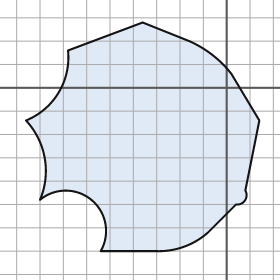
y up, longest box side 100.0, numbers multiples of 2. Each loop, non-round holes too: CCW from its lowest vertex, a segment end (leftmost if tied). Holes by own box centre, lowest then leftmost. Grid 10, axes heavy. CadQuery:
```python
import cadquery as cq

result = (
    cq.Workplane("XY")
    .moveTo(-54.0, -70.0)
    .lineTo(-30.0, -70.0)
    .threePointArc((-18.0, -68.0), (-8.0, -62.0))
    .lineTo(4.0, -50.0)
    .threePointArc((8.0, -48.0), (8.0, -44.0))
    .lineTo(14.0, -14.0)
    .lineTo(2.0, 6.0)
    .threePointArc((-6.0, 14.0), (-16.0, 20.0))
    .lineTo(-36.0, 28.0)
    .lineTo(-68.0, 16.0)
    .threePointArc((-72.0, -2.0), (-86.0, -14.0))
    .threePointArc((-78.0, -30.0), (-80.0, -48.0))
    .threePointArc((-58.0, -48.0), (-54.0, -70.0))
    .close()
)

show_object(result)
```